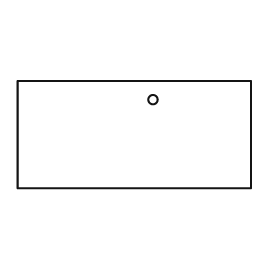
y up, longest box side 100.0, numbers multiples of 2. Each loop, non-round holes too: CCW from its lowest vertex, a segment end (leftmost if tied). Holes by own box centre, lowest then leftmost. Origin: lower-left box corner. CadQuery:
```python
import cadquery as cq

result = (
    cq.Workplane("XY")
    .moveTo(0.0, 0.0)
    .lineTo(100.0, 0.0)
    .lineTo(100.0, 46.0)
    .lineTo(0.0, 46.0)
    .close()
    .moveTo(58.0, 38.0)
    .circle(2.0)
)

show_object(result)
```